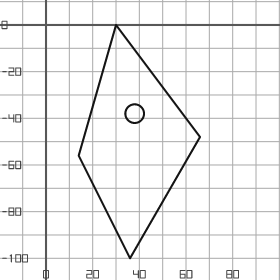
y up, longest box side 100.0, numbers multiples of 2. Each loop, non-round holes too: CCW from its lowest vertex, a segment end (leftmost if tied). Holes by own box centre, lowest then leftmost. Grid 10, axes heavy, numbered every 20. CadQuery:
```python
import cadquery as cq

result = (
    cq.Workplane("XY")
    .moveTo(36.0, -100.0)
    .lineTo(66.0, -48.0)
    .lineTo(30.0, 0.0)
    .lineTo(14.0, -56.0)
    .close()
    .moveTo(38.0, -38.0)
    .circle(4.0)
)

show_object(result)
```